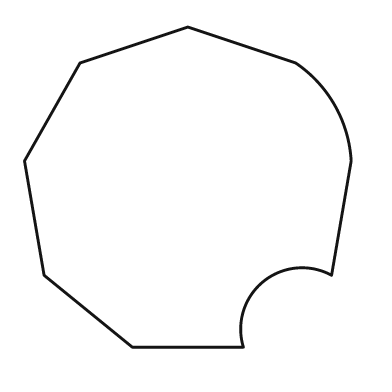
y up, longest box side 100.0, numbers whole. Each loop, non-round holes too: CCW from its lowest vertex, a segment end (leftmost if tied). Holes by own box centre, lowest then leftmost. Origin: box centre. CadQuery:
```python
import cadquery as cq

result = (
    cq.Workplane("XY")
    .moveTo(-17.0, -49.0)
    .lineTo(17.0, -49.0)
    .threePointArc((23.0, -29.0), (44.0, -27.0))
    .lineTo(50.0, 8.0)
    .threePointArc((45.0, 25.0), (33.0, 38.0))
    .lineTo(0.0, 49.0)
    .lineTo(-33.0, 38.0)
    .lineTo(-50.0, 8.0)
    .lineTo(-44.0, -27.0)
    .close()
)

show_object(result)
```